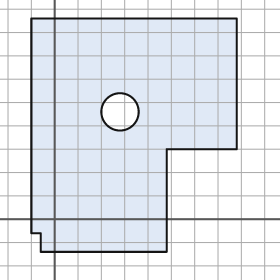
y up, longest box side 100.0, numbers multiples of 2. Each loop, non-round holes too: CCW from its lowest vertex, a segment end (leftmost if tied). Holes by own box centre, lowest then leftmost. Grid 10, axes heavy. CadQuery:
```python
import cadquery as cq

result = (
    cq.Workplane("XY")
    .moveTo(-6.0, -14.0)
    .lineTo(48.0, -14.0)
    .lineTo(48.0, 30.0)
    .lineTo(78.0, 30.0)
    .lineTo(78.0, 86.0)
    .lineTo(-10.0, 86.0)
    .lineTo(-10.0, -6.0)
    .lineTo(-6.0, -6.0)
    .close()
    .moveTo(28.0, 46.0)
    .circle(8.0)
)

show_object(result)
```